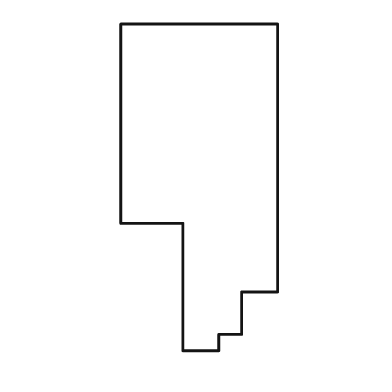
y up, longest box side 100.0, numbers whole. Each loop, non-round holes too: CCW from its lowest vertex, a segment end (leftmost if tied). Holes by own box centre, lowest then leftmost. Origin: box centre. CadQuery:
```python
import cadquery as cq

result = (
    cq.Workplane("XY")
    .moveTo(-5.0, -50.0)
    .lineTo(6.0, -50.0)
    .lineTo(6.0, -45.0)
    .lineTo(13.0, -45.0)
    .lineTo(13.0, -32.0)
    .lineTo(24.0, -32.0)
    .lineTo(24.0, 50.0)
    .lineTo(-24.0, 50.0)
    .lineTo(-24.0, -11.0)
    .lineTo(-5.0, -11.0)
    .close()
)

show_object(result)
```